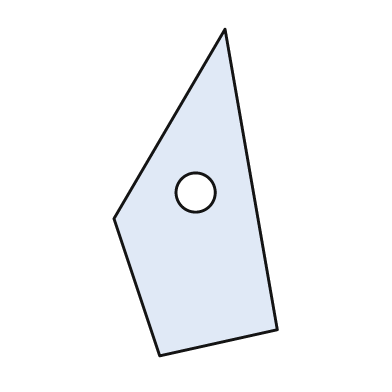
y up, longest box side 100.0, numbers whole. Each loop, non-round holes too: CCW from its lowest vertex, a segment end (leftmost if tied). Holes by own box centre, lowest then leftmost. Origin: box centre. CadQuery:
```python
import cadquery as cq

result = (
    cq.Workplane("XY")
    .moveTo(-11.0, -50.0)
    .lineTo(25.0, -42.0)
    .lineTo(9.0, 50.0)
    .lineTo(-25.0, -8.0)
    .close()
    .moveTo(0.0, 0.0)
    .circle(6.0)
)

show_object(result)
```